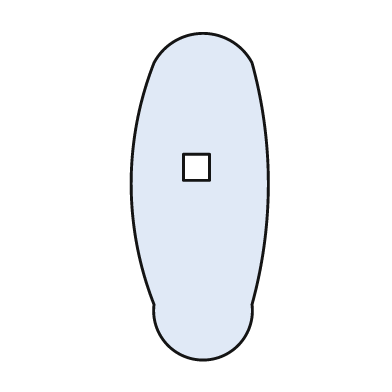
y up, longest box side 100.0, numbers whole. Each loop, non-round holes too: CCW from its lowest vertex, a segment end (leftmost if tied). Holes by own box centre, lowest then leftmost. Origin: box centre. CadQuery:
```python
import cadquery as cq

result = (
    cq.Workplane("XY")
    .moveTo(-14.0, -33.0)
    .threePointArc((1.0, -50.0), (16.0, -33.0))
    .threePointArc((21.0, 4.0), (16.0, 41.0))
    .threePointArc((1.0, 50.0), (-14.0, 41.0))
    .threePointArc((-21.0, 4.0), (-14.0, -33.0))
    .close()
    .moveTo(-5.0, 5.0)
    .lineTo(3.0, 5.0)
    .lineTo(3.0, 13.0)
    .lineTo(-5.0, 13.0)
    .close()
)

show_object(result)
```